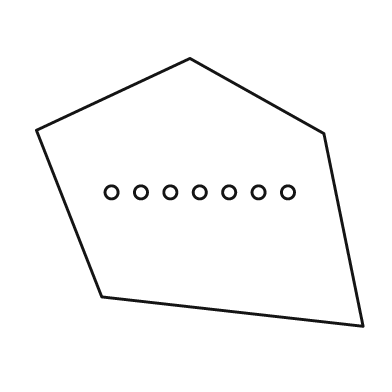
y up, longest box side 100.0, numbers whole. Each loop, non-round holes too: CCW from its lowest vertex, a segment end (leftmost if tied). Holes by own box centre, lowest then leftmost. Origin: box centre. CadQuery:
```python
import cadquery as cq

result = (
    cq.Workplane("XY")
    .moveTo(50.0, -41.0)
    .lineTo(38.0, 18.0)
    .lineTo(-3.0, 41.0)
    .lineTo(-50.0, 19.0)
    .lineTo(-30.0, -32.0)
    .close()
    .moveTo(-27.0, 0.0)
    .circle(2.0)
    .moveTo(-18.0, 0.0)
    .circle(2.0)
    .moveTo(-9.0, 0.0)
    .circle(2.0)
    .moveTo(0.0, 0.0)
    .circle(2.0)
    .moveTo(9.0, 0.0)
    .circle(2.0)
    .moveTo(18.0, 0.0)
    .circle(2.0)
    .moveTo(27.0, 0.0)
    .circle(2.0)
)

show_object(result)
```